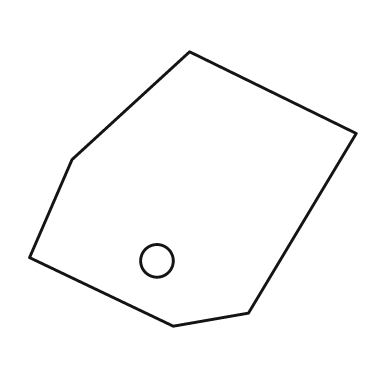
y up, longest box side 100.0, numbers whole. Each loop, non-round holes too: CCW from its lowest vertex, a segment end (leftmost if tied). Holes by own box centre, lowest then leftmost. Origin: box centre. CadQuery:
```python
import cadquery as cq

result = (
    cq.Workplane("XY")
    .moveTo(-6.0, -42.0)
    .lineTo(17.0, -38.0)
    .lineTo(50.0, 17.0)
    .lineTo(-1.0, 42.0)
    .lineTo(-37.0, 9.0)
    .lineTo(-50.0, -21.0)
    .close()
    .moveTo(-11.0, -22.0)
    .circle(5.0)
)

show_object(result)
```